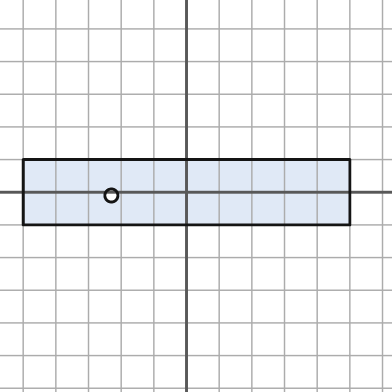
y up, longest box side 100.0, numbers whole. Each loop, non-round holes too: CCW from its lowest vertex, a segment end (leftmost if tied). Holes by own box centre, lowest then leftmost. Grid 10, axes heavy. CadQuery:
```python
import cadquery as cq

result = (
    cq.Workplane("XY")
    .moveTo(-50.0, -10.0)
    .lineTo(50.0, -10.0)
    .lineTo(50.0, 10.0)
    .lineTo(-50.0, 10.0)
    .close()
    .moveTo(-23.0, -1.0)
    .circle(2.0)
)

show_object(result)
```